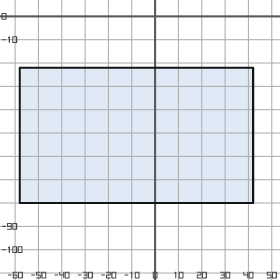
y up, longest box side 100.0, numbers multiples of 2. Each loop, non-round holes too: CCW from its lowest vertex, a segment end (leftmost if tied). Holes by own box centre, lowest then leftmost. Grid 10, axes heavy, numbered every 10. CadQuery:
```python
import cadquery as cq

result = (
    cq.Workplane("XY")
    .moveTo(-58.0, -80.0)
    .lineTo(42.0, -80.0)
    .lineTo(42.0, -22.0)
    .lineTo(-58.0, -22.0)
    .close()
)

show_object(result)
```